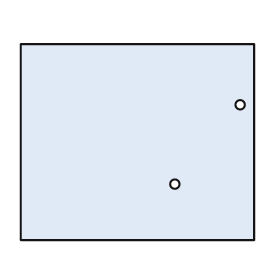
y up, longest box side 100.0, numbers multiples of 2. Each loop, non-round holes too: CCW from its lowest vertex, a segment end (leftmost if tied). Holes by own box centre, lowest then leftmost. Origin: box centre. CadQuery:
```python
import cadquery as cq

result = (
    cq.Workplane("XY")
    .moveTo(-50.0, -42.0)
    .lineTo(50.0, -42.0)
    .lineTo(50.0, 42.0)
    .lineTo(-50.0, 42.0)
    .close()
    .moveTo(16.0, -18.0)
    .circle(2.0)
    .moveTo(44.0, 16.0)
    .circle(2.0)
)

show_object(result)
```